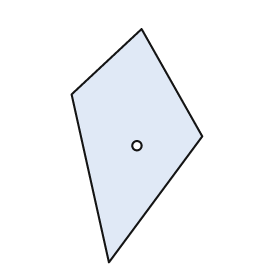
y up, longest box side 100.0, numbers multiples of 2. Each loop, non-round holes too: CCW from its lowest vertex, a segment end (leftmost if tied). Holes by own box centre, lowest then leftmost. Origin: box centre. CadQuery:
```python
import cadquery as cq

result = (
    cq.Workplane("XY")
    .moveTo(-12.0, -50.0)
    .lineTo(28.0, 4.0)
    .lineTo(2.0, 50.0)
    .lineTo(-28.0, 22.0)
    .close()
    .moveTo(0.0, 0.0)
    .circle(2.0)
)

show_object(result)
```